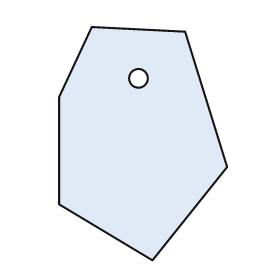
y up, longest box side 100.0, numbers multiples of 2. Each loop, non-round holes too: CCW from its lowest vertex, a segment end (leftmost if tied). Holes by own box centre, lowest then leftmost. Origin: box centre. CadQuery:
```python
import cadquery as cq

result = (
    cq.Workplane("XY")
    .moveTo(4.0, -50.0)
    .lineTo(36.0, -10.0)
    .lineTo(18.0, 48.0)
    .lineTo(-22.0, 50.0)
    .lineTo(-36.0, 20.0)
    .lineTo(-36.0, -26.0)
    .close()
    .moveTo(-2.0, 28.0)
    .circle(4.0)
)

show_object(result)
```